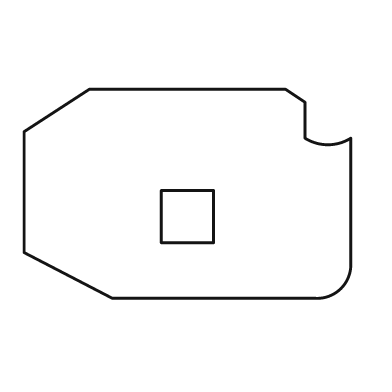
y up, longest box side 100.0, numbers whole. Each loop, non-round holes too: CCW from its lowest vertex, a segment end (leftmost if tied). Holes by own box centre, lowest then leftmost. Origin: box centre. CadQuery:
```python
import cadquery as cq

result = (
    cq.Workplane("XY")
    .moveTo(-23.0, -32.0)
    .lineTo(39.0, -32.0)
    .threePointArc((47.0, -29.0), (50.0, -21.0))
    .lineTo(50.0, 17.0)
    .threePointArc((43.0, 15.0), (36.0, 17.0))
    .lineTo(36.0, 28.0)
    .lineTo(30.0, 32.0)
    .lineTo(-30.0, 32.0)
    .lineTo(-50.0, 19.0)
    .lineTo(-50.0, -18.0)
    .close()
    .moveTo(-8.0, -15.0)
    .lineTo(8.0, -15.0)
    .lineTo(8.0, 1.0)
    .lineTo(-8.0, 1.0)
    .close()
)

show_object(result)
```